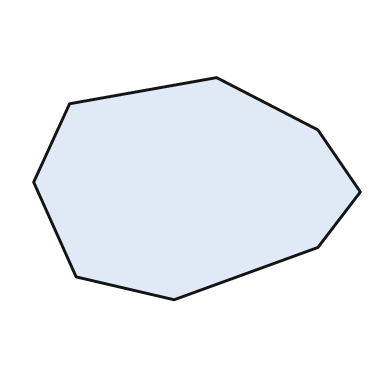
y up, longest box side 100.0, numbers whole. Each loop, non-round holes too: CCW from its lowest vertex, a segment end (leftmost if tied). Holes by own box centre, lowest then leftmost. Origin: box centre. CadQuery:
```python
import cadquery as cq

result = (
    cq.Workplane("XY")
    .moveTo(-7.0, -34.0)
    .lineTo(37.0, -18.0)
    .lineTo(50.0, -1.0)
    .lineTo(37.0, 18.0)
    .lineTo(6.0, 34.0)
    .lineTo(-39.0, 26.0)
    .lineTo(-50.0, 2.0)
    .lineTo(-37.0, -27.0)
    .close()
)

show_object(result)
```